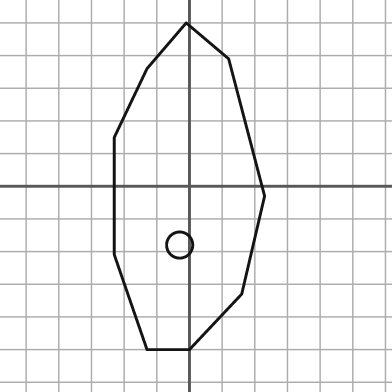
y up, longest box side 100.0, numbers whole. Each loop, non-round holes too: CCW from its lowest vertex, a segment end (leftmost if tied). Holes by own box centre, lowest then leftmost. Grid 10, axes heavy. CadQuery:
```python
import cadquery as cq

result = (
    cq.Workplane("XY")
    .moveTo(-13.0, -50.0)
    .lineTo(0.0, -50.0)
    .lineTo(16.0, -33.0)
    .lineTo(23.0, -3.0)
    .lineTo(12.0, 39.0)
    .lineTo(-1.0, 50.0)
    .lineTo(-13.0, 36.0)
    .lineTo(-23.0, 15.0)
    .lineTo(-23.0, -21.0)
    .close()
    .moveTo(-3.0, -18.0)
    .circle(4.0)
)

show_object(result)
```